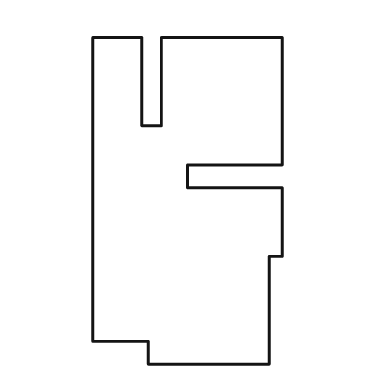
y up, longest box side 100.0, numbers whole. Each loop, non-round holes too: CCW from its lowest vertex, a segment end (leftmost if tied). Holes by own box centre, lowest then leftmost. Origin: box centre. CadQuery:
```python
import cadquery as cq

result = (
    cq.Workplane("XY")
    .moveTo(-12.0, -50.0)
    .lineTo(25.0, -50.0)
    .lineTo(25.0, -17.0)
    .lineTo(29.0, -17.0)
    .lineTo(29.0, 4.0)
    .lineTo(0.0, 4.0)
    .lineTo(0.0, 11.0)
    .lineTo(29.0, 11.0)
    .lineTo(29.0, 50.0)
    .lineTo(-8.0, 50.0)
    .lineTo(-8.0, 23.0)
    .lineTo(-14.0, 23.0)
    .lineTo(-14.0, 50.0)
    .lineTo(-29.0, 50.0)
    .lineTo(-29.0, -43.0)
    .lineTo(-12.0, -43.0)
    .close()
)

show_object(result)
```